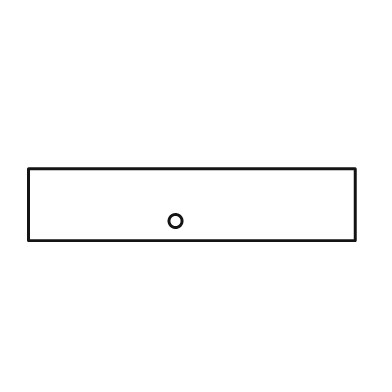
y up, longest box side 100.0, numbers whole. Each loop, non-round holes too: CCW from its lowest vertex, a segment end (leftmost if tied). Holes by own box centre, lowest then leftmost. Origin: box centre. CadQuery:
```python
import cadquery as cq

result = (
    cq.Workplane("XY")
    .moveTo(-50.0, -11.0)
    .lineTo(50.0, -11.0)
    .lineTo(50.0, 11.0)
    .lineTo(-50.0, 11.0)
    .close()
    .moveTo(-5.0, -5.0)
    .circle(2.0)
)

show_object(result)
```